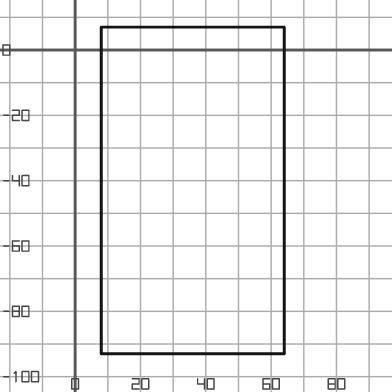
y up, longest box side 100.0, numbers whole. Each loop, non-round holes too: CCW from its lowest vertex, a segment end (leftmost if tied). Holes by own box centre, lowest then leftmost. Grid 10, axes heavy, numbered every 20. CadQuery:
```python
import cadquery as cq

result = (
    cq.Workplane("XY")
    .moveTo(8.0, -93.0)
    .lineTo(64.0, -93.0)
    .lineTo(64.0, 7.0)
    .lineTo(8.0, 7.0)
    .close()
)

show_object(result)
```